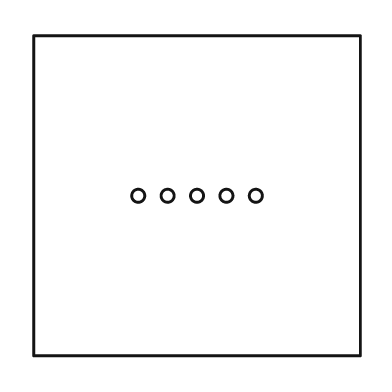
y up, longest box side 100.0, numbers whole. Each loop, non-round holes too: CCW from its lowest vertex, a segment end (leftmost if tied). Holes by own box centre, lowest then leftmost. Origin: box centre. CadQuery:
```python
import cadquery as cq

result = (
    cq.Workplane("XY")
    .moveTo(-50.0, -49.0)
    .lineTo(50.0, -49.0)
    .lineTo(50.0, 49.0)
    .lineTo(-50.0, 49.0)
    .close()
    .moveTo(-18.0, 0.0)
    .circle(2.0)
    .moveTo(-9.0, 0.0)
    .circle(2.0)
    .moveTo(0.0, 0.0)
    .circle(2.0)
    .moveTo(9.0, 0.0)
    .circle(2.0)
    .moveTo(18.0, 0.0)
    .circle(2.0)
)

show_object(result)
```